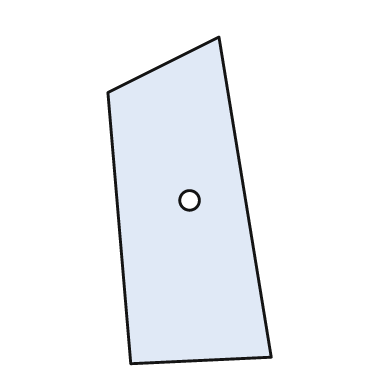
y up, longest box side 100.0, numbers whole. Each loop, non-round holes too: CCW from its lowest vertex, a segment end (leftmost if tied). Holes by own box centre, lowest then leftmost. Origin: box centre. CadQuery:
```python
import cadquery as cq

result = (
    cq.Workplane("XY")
    .moveTo(-18.0, -50.0)
    .lineTo(25.0, -48.0)
    .lineTo(9.0, 50.0)
    .lineTo(-25.0, 33.0)
    .close()
    .moveTo(0.0, 0.0)
    .circle(3.0)
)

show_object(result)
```